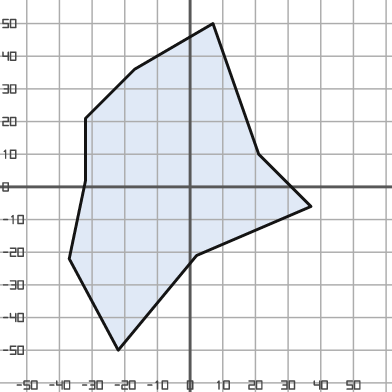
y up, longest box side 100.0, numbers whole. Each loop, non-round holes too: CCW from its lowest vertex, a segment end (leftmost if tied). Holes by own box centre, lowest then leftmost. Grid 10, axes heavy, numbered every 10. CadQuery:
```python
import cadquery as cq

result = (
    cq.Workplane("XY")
    .moveTo(-22.0, -50.0)
    .lineTo(2.0, -21.0)
    .lineTo(37.0, -6.0)
    .lineTo(21.0, 10.0)
    .lineTo(7.0, 50.0)
    .lineTo(-17.0, 36.0)
    .lineTo(-32.0, 21.0)
    .lineTo(-32.0, 2.0)
    .lineTo(-37.0, -22.0)
    .close()
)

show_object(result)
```